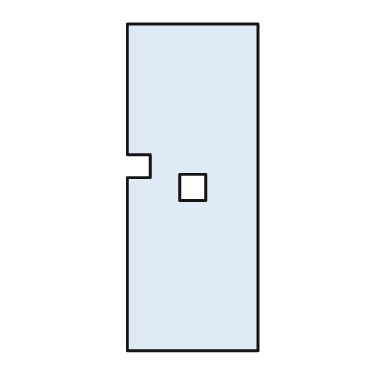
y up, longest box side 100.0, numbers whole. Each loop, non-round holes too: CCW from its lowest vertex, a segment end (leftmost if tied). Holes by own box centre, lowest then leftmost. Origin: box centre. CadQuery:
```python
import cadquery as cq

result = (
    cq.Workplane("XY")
    .moveTo(-20.0, -50.0)
    .lineTo(20.0, -50.0)
    .lineTo(20.0, 50.0)
    .lineTo(-20.0, 50.0)
    .lineTo(-20.0, 10.0)
    .lineTo(-13.0, 10.0)
    .lineTo(-13.0, 3.0)
    .lineTo(-20.0, 3.0)
    .close()
    .moveTo(-4.0, -4.0)
    .lineTo(4.0, -4.0)
    .lineTo(4.0, 4.0)
    .lineTo(-4.0, 4.0)
    .close()
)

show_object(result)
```